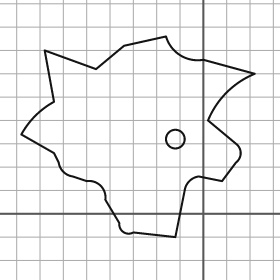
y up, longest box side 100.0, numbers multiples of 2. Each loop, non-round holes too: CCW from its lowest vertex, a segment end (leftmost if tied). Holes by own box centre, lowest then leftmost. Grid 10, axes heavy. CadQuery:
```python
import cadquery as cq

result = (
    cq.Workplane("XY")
    .moveTo(-12.0, -10.0)
    .lineTo(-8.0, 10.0)
    .threePointArc((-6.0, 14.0), (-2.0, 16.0))
    .lineTo(8.0, 14.0)
    .lineTo(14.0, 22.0)
    .threePointArc((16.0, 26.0), (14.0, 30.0))
    .lineTo(2.0, 40.0)
    .threePointArc((10.0, 52.0), (22.0, 60.0))
    .lineTo(0.0, 66.0)
    .threePointArc((-10.0, 68.0), (-16.0, 76.0))
    .lineTo(-34.0, 72.0)
    .lineTo(-46.0, 62.0)
    .lineTo(-68.0, 70.0)
    .lineTo(-64.0, 48.0)
    .threePointArc((-72.0, 42.0), (-78.0, 34.0))
    .lineTo(-64.0, 26.0)
    .lineTo(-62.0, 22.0)
    .threePointArc((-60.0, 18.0), (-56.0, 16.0))
    .lineTo(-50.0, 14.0)
    .threePointArc((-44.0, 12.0), (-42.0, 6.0))
    .lineTo(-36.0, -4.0)
    .threePointArc((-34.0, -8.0), (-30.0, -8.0))
    .close()
    .moveTo(-12.0, 32.0)
    .circle(4.0)
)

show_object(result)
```